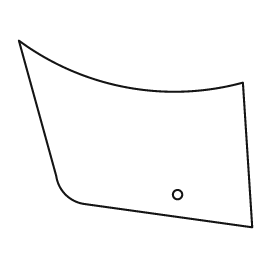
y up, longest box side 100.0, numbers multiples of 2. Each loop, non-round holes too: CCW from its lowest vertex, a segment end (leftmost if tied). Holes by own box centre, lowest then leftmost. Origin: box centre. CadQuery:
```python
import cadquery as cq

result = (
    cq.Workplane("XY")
    .moveTo(50.0, -40.0)
    .lineTo(46.0, 22.0)
    .threePointArc((-4.0, 20.0), (-50.0, 40.0))
    .lineTo(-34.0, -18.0)
    .threePointArc((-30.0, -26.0), (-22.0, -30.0))
    .close()
    .moveTo(18.0, -26.0)
    .circle(2.0)
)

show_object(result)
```